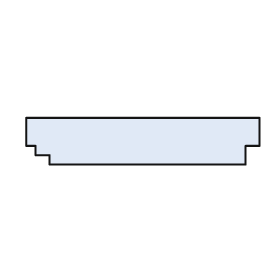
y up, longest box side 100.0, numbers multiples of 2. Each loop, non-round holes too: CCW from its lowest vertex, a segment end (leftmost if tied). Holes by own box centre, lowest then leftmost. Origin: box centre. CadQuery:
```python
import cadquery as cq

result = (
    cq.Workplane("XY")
    .moveTo(-40.0, -10.0)
    .lineTo(44.0, -10.0)
    .lineTo(44.0, -2.0)
    .lineTo(50.0, -2.0)
    .lineTo(50.0, 10.0)
    .lineTo(-50.0, 10.0)
    .lineTo(-50.0, -2.0)
    .lineTo(-46.0, -2.0)
    .lineTo(-46.0, -6.0)
    .lineTo(-40.0, -6.0)
    .close()
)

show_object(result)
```